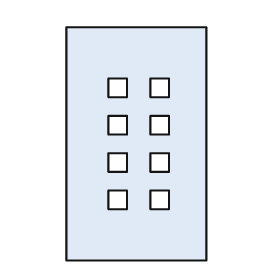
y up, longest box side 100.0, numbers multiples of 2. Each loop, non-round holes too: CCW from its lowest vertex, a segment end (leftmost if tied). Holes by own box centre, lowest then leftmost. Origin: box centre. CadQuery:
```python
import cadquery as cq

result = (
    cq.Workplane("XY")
    .moveTo(-30.0, -50.0)
    .lineTo(30.0, -50.0)
    .lineTo(30.0, 50.0)
    .lineTo(-30.0, 50.0)
    .close()
    .moveTo(-12.0, -28.0)
    .lineTo(-4.0, -28.0)
    .lineTo(-4.0, -20.0)
    .lineTo(-12.0, -20.0)
    .close()
    .moveTo(6.0, -28.0)
    .lineTo(14.0, -28.0)
    .lineTo(14.0, -20.0)
    .lineTo(6.0, -20.0)
    .close()
    .moveTo(-12.0, -12.0)
    .lineTo(-4.0, -12.0)
    .lineTo(-4.0, -4.0)
    .lineTo(-12.0, -4.0)
    .close()
    .moveTo(6.0, -12.0)
    .lineTo(14.0, -12.0)
    .lineTo(14.0, -4.0)
    .lineTo(6.0, -4.0)
    .close()
    .moveTo(-12.0, 4.0)
    .lineTo(-4.0, 4.0)
    .lineTo(-4.0, 12.0)
    .lineTo(-12.0, 12.0)
    .close()
    .moveTo(6.0, 4.0)
    .lineTo(14.0, 4.0)
    .lineTo(14.0, 12.0)
    .lineTo(6.0, 12.0)
    .close()
    .moveTo(-12.0, 20.0)
    .lineTo(-4.0, 20.0)
    .lineTo(-4.0, 28.0)
    .lineTo(-12.0, 28.0)
    .close()
    .moveTo(6.0, 20.0)
    .lineTo(14.0, 20.0)
    .lineTo(14.0, 28.0)
    .lineTo(6.0, 28.0)
    .close()
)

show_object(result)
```